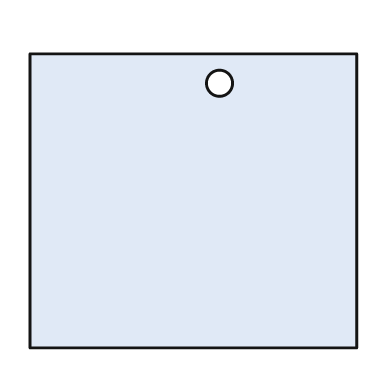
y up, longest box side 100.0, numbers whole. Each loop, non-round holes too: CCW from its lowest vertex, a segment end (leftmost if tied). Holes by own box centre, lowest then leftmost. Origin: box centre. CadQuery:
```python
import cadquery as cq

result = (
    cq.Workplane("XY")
    .moveTo(-50.0, -45.0)
    .lineTo(50.0, -45.0)
    .lineTo(50.0, 45.0)
    .lineTo(-50.0, 45.0)
    .close()
    .moveTo(8.0, 36.0)
    .circle(4.0)
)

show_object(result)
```